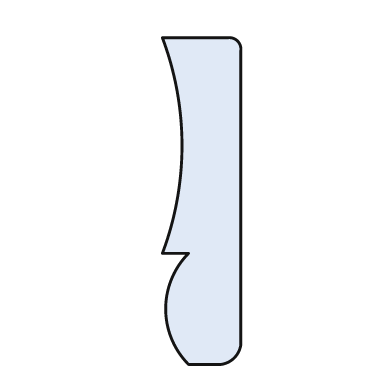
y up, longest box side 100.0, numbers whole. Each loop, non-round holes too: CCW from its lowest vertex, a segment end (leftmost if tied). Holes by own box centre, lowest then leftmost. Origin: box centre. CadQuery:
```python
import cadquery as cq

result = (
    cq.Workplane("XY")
    .moveTo(-4.0, -50.0)
    .lineTo(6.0, -50.0)
    .threePointArc((10.0, -48.0), (12.0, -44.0))
    .lineTo(12.0, 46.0)
    .threePointArc((11.0, 49.0), (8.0, 50.0))
    .lineTo(-12.0, 50.0)
    .threePointArc((-6.0, 17.0), (-12.0, -16.0))
    .lineTo(-4.0, -16.0)
    .threePointArc((-11.0, -33.0), (-4.0, -50.0))
    .close()
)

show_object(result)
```